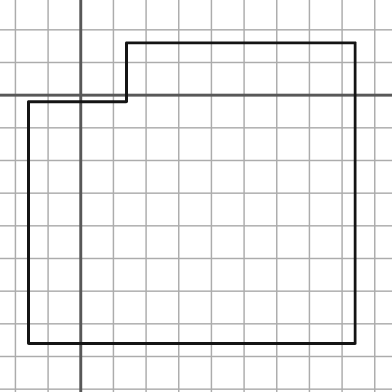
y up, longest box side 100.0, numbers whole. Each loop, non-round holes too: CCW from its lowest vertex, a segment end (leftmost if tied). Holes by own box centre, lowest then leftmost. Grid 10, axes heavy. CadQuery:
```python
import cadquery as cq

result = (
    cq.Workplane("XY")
    .moveTo(-16.0, -76.0)
    .lineTo(84.0, -76.0)
    .lineTo(84.0, 16.0)
    .lineTo(14.0, 16.0)
    .lineTo(14.0, -2.0)
    .lineTo(-16.0, -2.0)
    .close()
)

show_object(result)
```